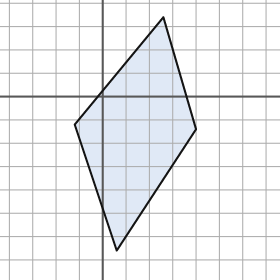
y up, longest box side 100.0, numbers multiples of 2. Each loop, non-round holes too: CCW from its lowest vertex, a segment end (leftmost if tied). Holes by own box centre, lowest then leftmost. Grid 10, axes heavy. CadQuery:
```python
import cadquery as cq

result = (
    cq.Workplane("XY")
    .moveTo(6.0, -66.0)
    .lineTo(40.0, -14.0)
    .lineTo(26.0, 34.0)
    .lineTo(-12.0, -12.0)
    .close()
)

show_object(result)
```